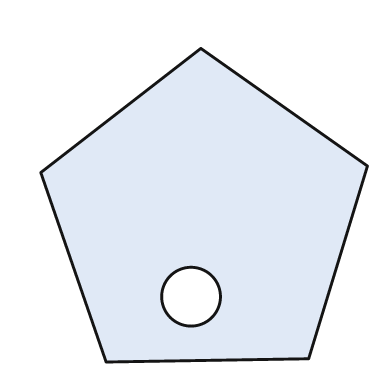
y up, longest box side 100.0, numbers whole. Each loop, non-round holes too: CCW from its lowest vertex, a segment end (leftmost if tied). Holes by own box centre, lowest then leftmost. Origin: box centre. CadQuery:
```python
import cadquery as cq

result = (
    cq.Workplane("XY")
    .moveTo(-30.0, -48.0)
    .lineTo(32.0, -47.0)
    .lineTo(50.0, 12.0)
    .lineTo(-1.0, 48.0)
    .lineTo(-50.0, 10.0)
    .close()
    .moveTo(-4.0, -28.0)
    .circle(9.0)
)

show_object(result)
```